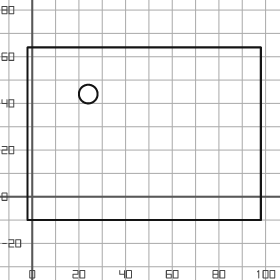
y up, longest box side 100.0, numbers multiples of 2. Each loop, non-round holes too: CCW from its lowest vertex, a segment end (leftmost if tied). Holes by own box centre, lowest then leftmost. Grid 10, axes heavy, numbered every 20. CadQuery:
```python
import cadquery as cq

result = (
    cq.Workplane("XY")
    .moveTo(-2.0, -10.0)
    .lineTo(98.0, -10.0)
    .lineTo(98.0, 64.0)
    .lineTo(-2.0, 64.0)
    .close()
    .moveTo(24.0, 44.0)
    .circle(4.0)
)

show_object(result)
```